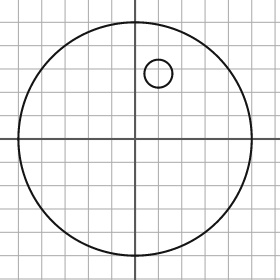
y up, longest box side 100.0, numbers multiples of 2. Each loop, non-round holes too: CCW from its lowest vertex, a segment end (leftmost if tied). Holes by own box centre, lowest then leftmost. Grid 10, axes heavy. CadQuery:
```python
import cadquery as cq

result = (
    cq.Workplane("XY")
    .moveTo(0.0, 0.0)
    .circle(50.0)
    .moveTo(10.0, 28.0)
    .circle(6.0)
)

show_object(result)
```